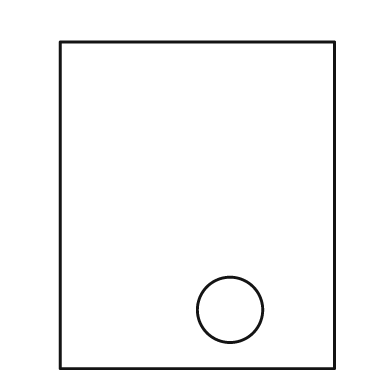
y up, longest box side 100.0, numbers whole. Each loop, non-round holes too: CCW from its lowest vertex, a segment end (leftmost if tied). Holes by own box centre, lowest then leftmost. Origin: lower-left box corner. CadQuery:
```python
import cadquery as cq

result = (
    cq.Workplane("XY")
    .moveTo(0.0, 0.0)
    .lineTo(84.0, 0.0)
    .lineTo(84.0, 100.0)
    .lineTo(0.0, 100.0)
    .close()
    .moveTo(52.0, 18.0)
    .circle(10.0)
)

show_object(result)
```